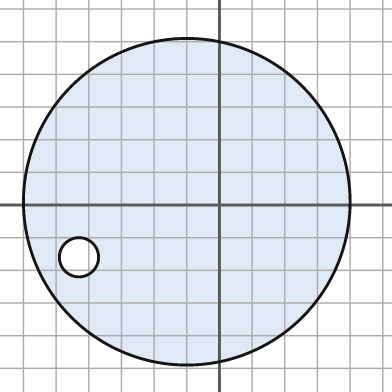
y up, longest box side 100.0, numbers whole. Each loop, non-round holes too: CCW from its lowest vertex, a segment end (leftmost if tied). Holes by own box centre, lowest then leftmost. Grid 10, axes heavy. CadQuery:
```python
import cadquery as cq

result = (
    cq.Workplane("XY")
    .moveTo(-10.0, 1.0)
    .circle(50.0)
    .moveTo(-43.0, -16.0)
    .circle(6.0)
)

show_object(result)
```